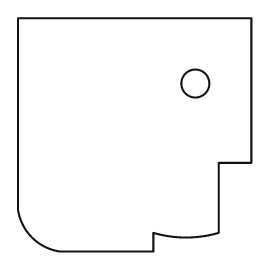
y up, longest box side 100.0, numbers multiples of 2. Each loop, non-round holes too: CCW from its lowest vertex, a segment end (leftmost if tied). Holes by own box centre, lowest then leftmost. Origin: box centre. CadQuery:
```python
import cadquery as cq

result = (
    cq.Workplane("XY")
    .moveTo(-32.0, -50.0)
    .lineTo(8.0, -50.0)
    .lineTo(8.0, -42.0)
    .threePointArc((22.0, -44.0), (36.0, -42.0))
    .lineTo(36.0, -12.0)
    .lineTo(50.0, -12.0)
    .lineTo(50.0, 50.0)
    .lineTo(-50.0, 50.0)
    .lineTo(-50.0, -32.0)
    .threePointArc((-44.0, -44.0), (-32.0, -50.0))
    .close()
    .moveTo(26.0, 22.0)
    .circle(6.0)
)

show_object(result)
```